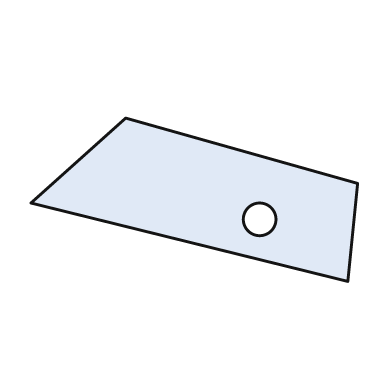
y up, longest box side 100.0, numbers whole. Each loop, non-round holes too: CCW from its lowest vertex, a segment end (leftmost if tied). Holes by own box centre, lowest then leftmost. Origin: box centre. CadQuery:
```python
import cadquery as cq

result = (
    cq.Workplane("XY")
    .moveTo(47.0, -25.0)
    .lineTo(50.0, 5.0)
    .lineTo(-21.0, 25.0)
    .lineTo(-50.0, -1.0)
    .close()
    .moveTo(20.0, -6.0)
    .circle(5.0)
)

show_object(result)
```